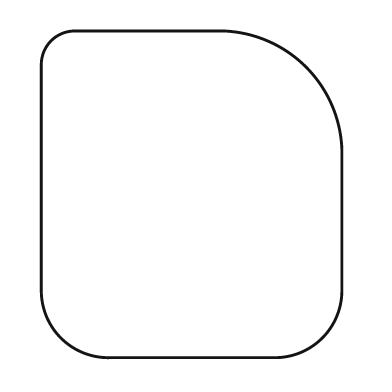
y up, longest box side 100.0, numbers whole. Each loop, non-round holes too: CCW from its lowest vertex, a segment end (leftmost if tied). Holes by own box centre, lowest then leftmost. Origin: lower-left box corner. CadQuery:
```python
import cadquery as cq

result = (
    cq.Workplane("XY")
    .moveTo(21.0, 0.0)
    .lineTo(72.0, 0.0)
    .threePointArc((86.0, 6.0), (92.0, 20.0))
    .lineTo(92.0, 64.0)
    .threePointArc((81.0, 89.0), (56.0, 100.0))
    .lineTo(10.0, 100.0)
    .threePointArc((3.0, 97.0), (0.0, 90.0))
    .lineTo(0.0, 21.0)
    .threePointArc((6.0, 6.0), (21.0, 0.0))
    .close()
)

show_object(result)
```